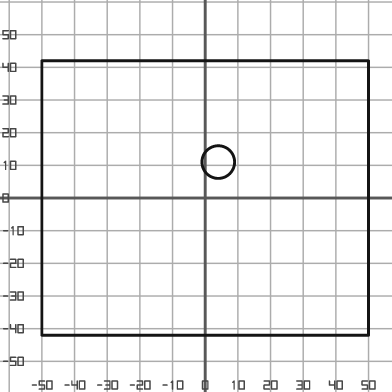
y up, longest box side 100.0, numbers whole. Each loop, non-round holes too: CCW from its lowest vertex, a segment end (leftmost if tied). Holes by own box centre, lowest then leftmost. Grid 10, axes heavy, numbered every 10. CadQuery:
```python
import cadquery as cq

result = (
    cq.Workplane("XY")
    .moveTo(-50.0, -42.0)
    .lineTo(50.0, -42.0)
    .lineTo(50.0, 42.0)
    .lineTo(-50.0, 42.0)
    .close()
    .moveTo(4.0, 11.0)
    .circle(5.0)
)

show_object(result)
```